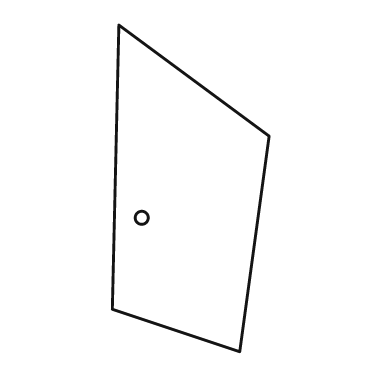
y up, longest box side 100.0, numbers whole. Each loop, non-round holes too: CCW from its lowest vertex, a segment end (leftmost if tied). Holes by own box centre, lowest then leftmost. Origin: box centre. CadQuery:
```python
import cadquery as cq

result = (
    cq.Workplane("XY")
    .moveTo(15.0, -50.0)
    .lineTo(24.0, 16.0)
    .lineTo(-22.0, 50.0)
    .lineTo(-24.0, -37.0)
    .close()
    .moveTo(-15.0, -9.0)
    .circle(2.0)
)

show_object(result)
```